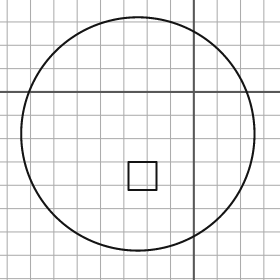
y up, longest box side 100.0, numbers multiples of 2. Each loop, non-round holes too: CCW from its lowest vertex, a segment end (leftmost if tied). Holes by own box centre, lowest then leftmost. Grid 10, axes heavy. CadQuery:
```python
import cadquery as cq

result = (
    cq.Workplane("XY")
    .moveTo(-24.0, -18.0)
    .circle(50.0)
    .moveTo(-28.0, -42.0)
    .lineTo(-16.0, -42.0)
    .lineTo(-16.0, -30.0)
    .lineTo(-28.0, -30.0)
    .close()
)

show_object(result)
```